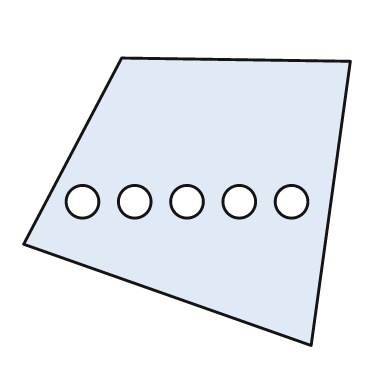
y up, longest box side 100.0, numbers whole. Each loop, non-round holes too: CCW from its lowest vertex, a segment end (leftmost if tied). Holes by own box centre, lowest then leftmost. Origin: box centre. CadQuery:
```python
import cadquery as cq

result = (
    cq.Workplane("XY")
    .moveTo(38.0, -44.0)
    .lineTo(50.0, 43.0)
    .lineTo(-20.0, 44.0)
    .lineTo(-50.0, -13.0)
    .close()
    .moveTo(-32.0, 0.0)
    .circle(5.0)
    .moveTo(-16.0, 0.0)
    .circle(5.0)
    .moveTo(0.0, 0.0)
    .circle(5.0)
    .moveTo(16.0, 0.0)
    .circle(5.0)
    .moveTo(32.0, 0.0)
    .circle(5.0)
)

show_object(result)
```